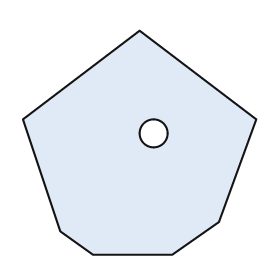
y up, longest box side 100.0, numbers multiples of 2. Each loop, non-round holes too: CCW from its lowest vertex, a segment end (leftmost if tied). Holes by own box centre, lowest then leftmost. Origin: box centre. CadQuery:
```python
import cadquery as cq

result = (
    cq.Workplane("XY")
    .moveTo(-20.0, -48.0)
    .lineTo(14.0, -48.0)
    .lineTo(34.0, -34.0)
    .lineTo(50.0, 10.0)
    .lineTo(0.0, 48.0)
    .lineTo(-50.0, 10.0)
    .lineTo(-34.0, -38.0)
    .close()
    .moveTo(6.0, 4.0)
    .circle(6.0)
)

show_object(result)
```